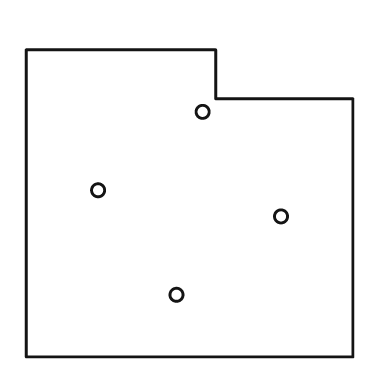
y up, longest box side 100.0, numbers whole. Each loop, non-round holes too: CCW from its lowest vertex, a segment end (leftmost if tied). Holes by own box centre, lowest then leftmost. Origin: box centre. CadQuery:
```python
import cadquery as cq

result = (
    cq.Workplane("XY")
    .moveTo(-50.0, -47.0)
    .lineTo(50.0, -47.0)
    .lineTo(50.0, 32.0)
    .lineTo(8.0, 32.0)
    .lineTo(8.0, 47.0)
    .lineTo(-50.0, 47.0)
    .close()
    .moveTo(-4.0, -28.0)
    .circle(2.0)
    .moveTo(28.0, -4.0)
    .circle(2.0)
    .moveTo(-28.0, 4.0)
    .circle(2.0)
    .moveTo(4.0, 28.0)
    .circle(2.0)
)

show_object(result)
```